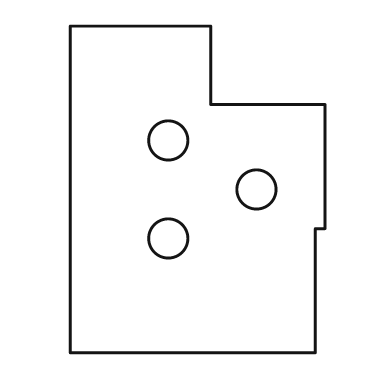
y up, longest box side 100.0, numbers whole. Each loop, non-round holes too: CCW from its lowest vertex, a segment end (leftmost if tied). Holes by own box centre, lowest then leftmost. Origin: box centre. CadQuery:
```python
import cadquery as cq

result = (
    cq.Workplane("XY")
    .moveTo(-39.0, -50.0)
    .lineTo(36.0, -50.0)
    .lineTo(36.0, -12.0)
    .lineTo(39.0, -12.0)
    .lineTo(39.0, 26.0)
    .lineTo(4.0, 26.0)
    .lineTo(4.0, 50.0)
    .lineTo(-39.0, 50.0)
    .close()
    .moveTo(-9.0, -15.0)
    .circle(6.0)
    .moveTo(18.0, 0.0)
    .circle(6.0)
    .moveTo(-9.0, 15.0)
    .circle(6.0)
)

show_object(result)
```